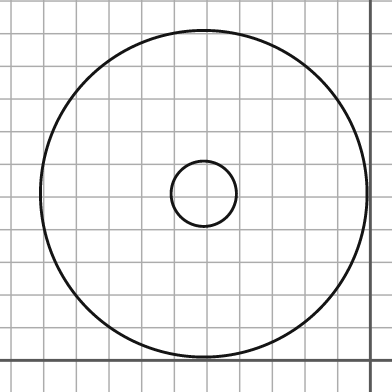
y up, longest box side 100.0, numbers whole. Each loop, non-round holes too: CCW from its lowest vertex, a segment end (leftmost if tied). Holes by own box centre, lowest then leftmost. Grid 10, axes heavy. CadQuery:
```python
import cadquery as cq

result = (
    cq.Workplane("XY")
    .moveTo(-51.0, 51.0)
    .circle(50.0)
    .moveTo(-51.0, 51.0)
    .circle(10.0)
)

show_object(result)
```